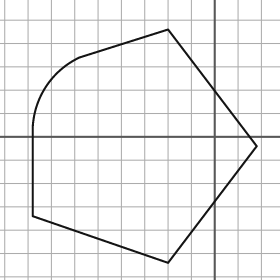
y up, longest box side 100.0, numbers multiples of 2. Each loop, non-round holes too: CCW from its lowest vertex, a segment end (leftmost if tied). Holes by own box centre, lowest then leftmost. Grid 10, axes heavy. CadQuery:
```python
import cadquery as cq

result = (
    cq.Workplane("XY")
    .moveTo(-20.0, -54.0)
    .lineTo(18.0, -4.0)
    .lineTo(-20.0, 46.0)
    .lineTo(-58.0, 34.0)
    .threePointArc((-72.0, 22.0), (-78.0, 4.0))
    .lineTo(-78.0, -34.0)
    .close()
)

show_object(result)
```